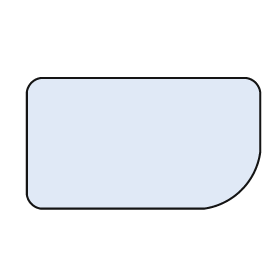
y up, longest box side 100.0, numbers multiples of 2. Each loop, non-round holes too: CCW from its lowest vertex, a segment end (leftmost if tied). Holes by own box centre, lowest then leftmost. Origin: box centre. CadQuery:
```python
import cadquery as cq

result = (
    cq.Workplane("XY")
    .moveTo(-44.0, -28.0)
    .lineTo(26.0, -28.0)
    .threePointArc((42.0, -20.0), (50.0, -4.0))
    .lineTo(50.0, 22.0)
    .threePointArc((48.0, 26.0), (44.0, 28.0))
    .lineTo(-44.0, 28.0)
    .threePointArc((-48.0, 26.0), (-50.0, 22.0))
    .lineTo(-50.0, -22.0)
    .threePointArc((-48.0, -26.0), (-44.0, -28.0))
    .close()
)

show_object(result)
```